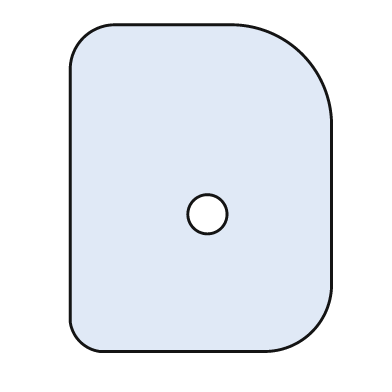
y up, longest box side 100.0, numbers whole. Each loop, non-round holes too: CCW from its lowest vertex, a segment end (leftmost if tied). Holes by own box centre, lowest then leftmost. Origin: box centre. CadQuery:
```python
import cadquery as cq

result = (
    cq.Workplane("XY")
    .moveTo(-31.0, -50.0)
    .lineTo(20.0, -50.0)
    .threePointArc((34.0, -44.0), (40.0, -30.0))
    .lineTo(40.0, 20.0)
    .threePointArc((31.0, 41.0), (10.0, 50.0))
    .lineTo(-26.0, 50.0)
    .threePointArc((-36.0, 46.0), (-40.0, 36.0))
    .lineTo(-40.0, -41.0)
    .threePointArc((-37.0, -47.0), (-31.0, -50.0))
    .close()
    .moveTo(2.0, -8.0)
    .circle(6.0)
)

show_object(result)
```